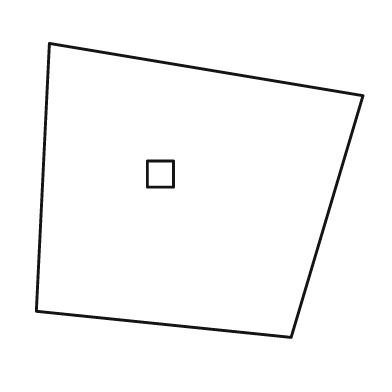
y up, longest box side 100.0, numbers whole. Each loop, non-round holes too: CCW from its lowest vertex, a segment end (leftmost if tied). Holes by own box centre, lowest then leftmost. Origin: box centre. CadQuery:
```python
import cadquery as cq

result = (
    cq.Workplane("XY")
    .moveTo(28.0, -45.0)
    .lineTo(50.0, 29.0)
    .lineTo(-46.0, 45.0)
    .lineTo(-50.0, -37.0)
    .close()
    .moveTo(-16.0, 1.0)
    .lineTo(-8.0, 1.0)
    .lineTo(-8.0, 9.0)
    .lineTo(-16.0, 9.0)
    .close()
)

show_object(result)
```